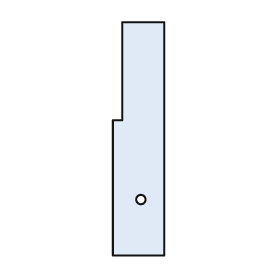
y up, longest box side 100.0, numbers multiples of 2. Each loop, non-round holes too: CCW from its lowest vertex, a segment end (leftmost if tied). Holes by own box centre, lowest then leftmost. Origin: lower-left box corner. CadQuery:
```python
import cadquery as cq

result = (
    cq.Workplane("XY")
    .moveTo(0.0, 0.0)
    .lineTo(22.0, 0.0)
    .lineTo(22.0, 100.0)
    .lineTo(4.0, 100.0)
    .lineTo(4.0, 58.0)
    .lineTo(0.0, 58.0)
    .close()
    .moveTo(12.0, 24.0)
    .circle(2.0)
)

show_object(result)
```